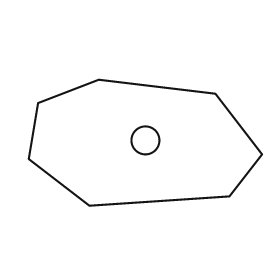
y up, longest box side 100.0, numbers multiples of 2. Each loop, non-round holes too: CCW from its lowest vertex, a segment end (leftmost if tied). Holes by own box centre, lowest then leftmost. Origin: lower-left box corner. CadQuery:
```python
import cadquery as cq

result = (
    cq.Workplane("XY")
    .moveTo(26.0, 0.0)
    .lineTo(86.0, 4.0)
    .lineTo(100.0, 22.0)
    .lineTo(80.0, 48.0)
    .lineTo(30.0, 54.0)
    .lineTo(4.0, 44.0)
    .lineTo(0.0, 20.0)
    .close()
    .moveTo(50.0, 28.0)
    .circle(6.0)
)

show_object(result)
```